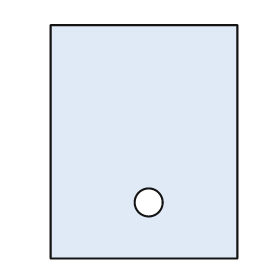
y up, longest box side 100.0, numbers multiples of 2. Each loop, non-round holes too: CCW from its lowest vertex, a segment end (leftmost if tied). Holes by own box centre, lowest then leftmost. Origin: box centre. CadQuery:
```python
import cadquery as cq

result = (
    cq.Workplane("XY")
    .moveTo(-40.0, -50.0)
    .lineTo(40.0, -50.0)
    .lineTo(40.0, 50.0)
    .lineTo(-40.0, 50.0)
    .close()
    .moveTo(2.0, -26.0)
    .circle(6.0)
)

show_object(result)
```